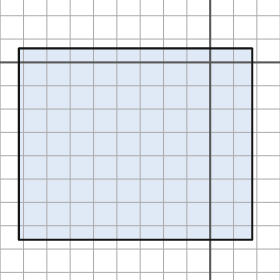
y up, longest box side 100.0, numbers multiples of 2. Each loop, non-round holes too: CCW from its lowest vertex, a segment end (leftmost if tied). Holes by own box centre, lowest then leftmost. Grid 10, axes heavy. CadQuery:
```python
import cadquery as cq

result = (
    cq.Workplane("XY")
    .moveTo(-82.0, -76.0)
    .lineTo(18.0, -76.0)
    .lineTo(18.0, 6.0)
    .lineTo(-82.0, 6.0)
    .close()
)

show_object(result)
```